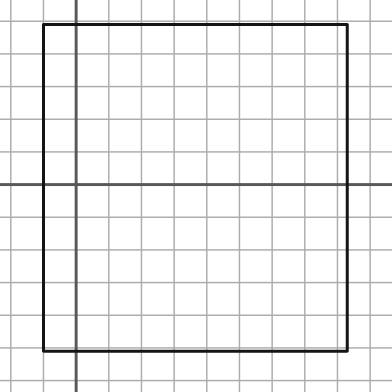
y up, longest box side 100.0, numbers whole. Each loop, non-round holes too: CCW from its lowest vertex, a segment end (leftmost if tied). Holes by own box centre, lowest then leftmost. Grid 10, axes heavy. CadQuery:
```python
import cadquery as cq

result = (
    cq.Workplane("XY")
    .moveTo(-10.0, -51.0)
    .lineTo(83.0, -51.0)
    .lineTo(83.0, 49.0)
    .lineTo(-10.0, 49.0)
    .close()
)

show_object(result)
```